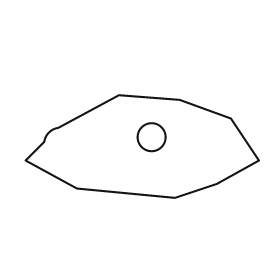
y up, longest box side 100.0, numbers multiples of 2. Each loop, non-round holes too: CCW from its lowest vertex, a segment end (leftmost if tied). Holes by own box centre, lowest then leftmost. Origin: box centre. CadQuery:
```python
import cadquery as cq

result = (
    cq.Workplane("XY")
    .moveTo(14.0, -22.0)
    .lineTo(32.0, -16.0)
    .lineTo(50.0, -6.0)
    .lineTo(38.0, 12.0)
    .lineTo(16.0, 20.0)
    .lineTo(-10.0, 22.0)
    .lineTo(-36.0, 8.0)
    .threePointArc((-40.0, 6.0), (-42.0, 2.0))
    .lineTo(-50.0, -6.0)
    .lineTo(-28.0, -18.0)
    .close()
    .moveTo(4.0, 4.0)
    .circle(6.0)
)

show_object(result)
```